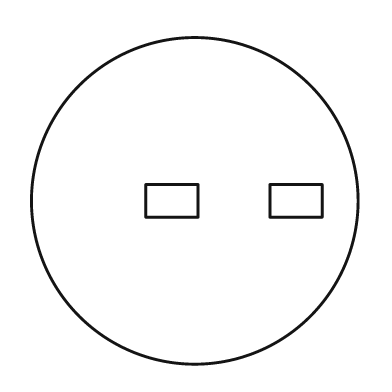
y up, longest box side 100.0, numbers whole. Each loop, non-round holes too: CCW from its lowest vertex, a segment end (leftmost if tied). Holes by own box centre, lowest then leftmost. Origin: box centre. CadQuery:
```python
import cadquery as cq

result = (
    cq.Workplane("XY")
    .moveTo(0.0, 0.0)
    .circle(50.0)
    .moveTo(-15.0, -5.0)
    .lineTo(1.0, -5.0)
    .lineTo(1.0, 5.0)
    .lineTo(-15.0, 5.0)
    .close()
    .moveTo(23.0, -5.0)
    .lineTo(39.0, -5.0)
    .lineTo(39.0, 5.0)
    .lineTo(23.0, 5.0)
    .close()
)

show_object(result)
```